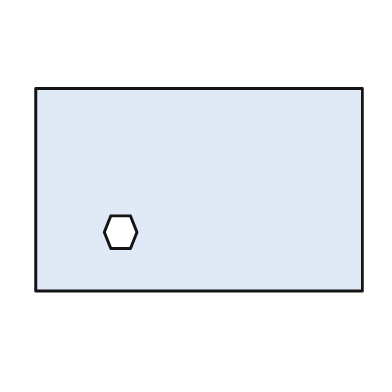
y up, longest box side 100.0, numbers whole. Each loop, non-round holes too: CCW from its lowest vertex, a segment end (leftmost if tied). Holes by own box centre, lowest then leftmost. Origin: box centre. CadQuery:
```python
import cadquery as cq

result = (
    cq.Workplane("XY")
    .moveTo(-50.0, -31.0)
    .lineTo(50.0, -31.0)
    .lineTo(50.0, 31.0)
    .lineTo(-50.0, 31.0)
    .close()
    .moveTo(-27.0, -18.0)
    .lineTo(-21.0, -18.0)
    .lineTo(-19.0, -13.0)
    .lineTo(-21.0, -8.0)
    .lineTo(-27.0, -8.0)
    .lineTo(-29.0, -13.0)
    .close()
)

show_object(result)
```